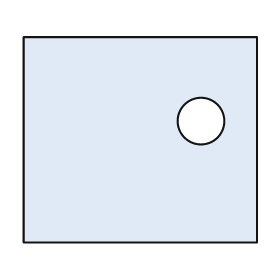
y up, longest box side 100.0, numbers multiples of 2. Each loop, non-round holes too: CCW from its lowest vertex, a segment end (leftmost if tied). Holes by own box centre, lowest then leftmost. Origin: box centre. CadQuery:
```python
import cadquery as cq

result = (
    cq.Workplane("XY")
    .moveTo(-50.0, -44.0)
    .lineTo(50.0, -44.0)
    .lineTo(50.0, 44.0)
    .lineTo(-50.0, 44.0)
    .close()
    .moveTo(26.0, 8.0)
    .circle(10.0)
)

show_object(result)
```